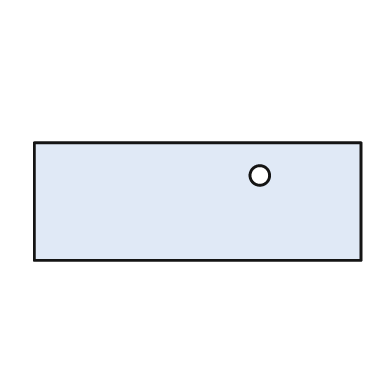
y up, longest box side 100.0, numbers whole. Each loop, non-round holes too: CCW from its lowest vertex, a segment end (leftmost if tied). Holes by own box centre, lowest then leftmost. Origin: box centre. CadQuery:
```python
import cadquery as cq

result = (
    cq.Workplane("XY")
    .moveTo(-50.0, -18.0)
    .lineTo(50.0, -18.0)
    .lineTo(50.0, 18.0)
    .lineTo(-50.0, 18.0)
    .close()
    .moveTo(19.0, 8.0)
    .circle(3.0)
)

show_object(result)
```